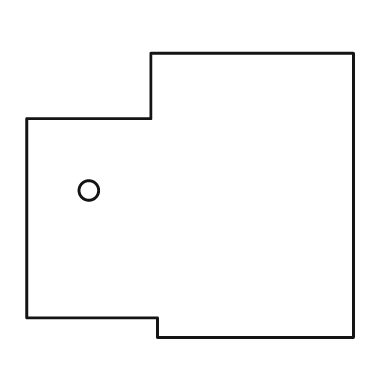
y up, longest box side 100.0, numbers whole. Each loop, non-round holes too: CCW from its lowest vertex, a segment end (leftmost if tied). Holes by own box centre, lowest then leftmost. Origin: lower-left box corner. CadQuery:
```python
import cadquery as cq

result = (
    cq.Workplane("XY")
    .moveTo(40.0, 0.0)
    .lineTo(100.0, 0.0)
    .lineTo(100.0, 87.0)
    .lineTo(38.0, 87.0)
    .lineTo(38.0, 67.0)
    .lineTo(0.0, 67.0)
    .lineTo(0.0, 6.0)
    .lineTo(40.0, 6.0)
    .close()
    .moveTo(19.0, 45.0)
    .circle(3.0)
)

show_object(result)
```